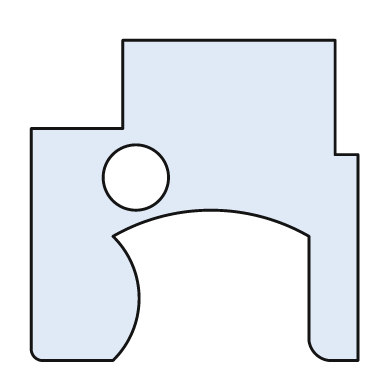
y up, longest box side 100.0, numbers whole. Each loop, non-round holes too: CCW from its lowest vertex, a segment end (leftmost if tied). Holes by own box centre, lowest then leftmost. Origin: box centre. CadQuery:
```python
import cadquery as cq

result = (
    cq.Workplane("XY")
    .moveTo(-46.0, -49.0)
    .lineTo(-25.0, -49.0)
    .threePointArc((-17.0, -30.0), (-25.0, -11.0))
    .threePointArc((5.0, -3.0), (35.0, -11.0))
    .lineTo(35.0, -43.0)
    .threePointArc((37.0, -47.0), (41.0, -49.0))
    .lineTo(50.0, -49.0)
    .lineTo(50.0, 14.0)
    .lineTo(43.0, 14.0)
    .lineTo(43.0, 49.0)
    .lineTo(-22.0, 49.0)
    .lineTo(-22.0, 22.0)
    .lineTo(-50.0, 22.0)
    .lineTo(-50.0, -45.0)
    .threePointArc((-49.0, -48.0), (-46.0, -49.0))
    .close()
    .moveTo(-18.0, 7.0)
    .circle(10.0)
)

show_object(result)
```